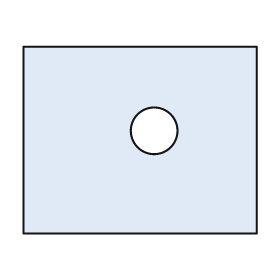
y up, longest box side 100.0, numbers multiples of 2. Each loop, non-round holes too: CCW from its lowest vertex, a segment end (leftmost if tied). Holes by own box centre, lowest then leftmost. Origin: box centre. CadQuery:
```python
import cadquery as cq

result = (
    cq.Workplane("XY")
    .moveTo(-50.0, -40.0)
    .lineTo(50.0, -40.0)
    .lineTo(50.0, 40.0)
    .lineTo(-50.0, 40.0)
    .close()
    .moveTo(6.0, 4.0)
    .circle(10.0)
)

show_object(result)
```